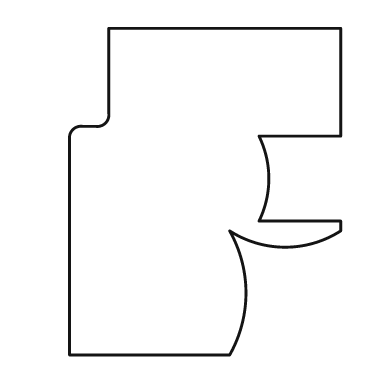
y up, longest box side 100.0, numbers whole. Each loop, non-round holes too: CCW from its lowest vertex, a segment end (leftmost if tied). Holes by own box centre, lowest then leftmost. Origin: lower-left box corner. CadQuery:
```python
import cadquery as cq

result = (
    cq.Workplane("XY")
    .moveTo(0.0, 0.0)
    .lineTo(49.0, 0.0)
    .threePointArc((54.0, 19.0), (49.0, 38.0))
    .threePointArc((66.0, 33.0), (83.0, 38.0))
    .lineTo(83.0, 41.0)
    .lineTo(58.0, 41.0)
    .threePointArc((61.0, 54.0), (58.0, 67.0))
    .lineTo(83.0, 67.0)
    .lineTo(83.0, 100.0)
    .lineTo(12.0, 100.0)
    .lineTo(12.0, 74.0)
    .threePointArc((11.0, 71.0), (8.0, 70.0))
    .lineTo(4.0, 70.0)
    .threePointArc((1.0, 69.0), (0.0, 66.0))
    .close()
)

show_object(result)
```